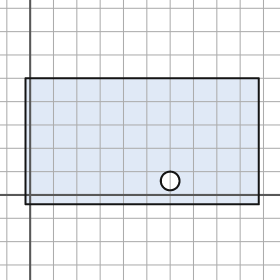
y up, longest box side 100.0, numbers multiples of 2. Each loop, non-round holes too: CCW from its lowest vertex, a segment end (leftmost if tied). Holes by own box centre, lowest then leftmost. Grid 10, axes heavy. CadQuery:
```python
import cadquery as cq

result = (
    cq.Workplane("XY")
    .moveTo(-2.0, -4.0)
    .lineTo(98.0, -4.0)
    .lineTo(98.0, 50.0)
    .lineTo(-2.0, 50.0)
    .close()
    .moveTo(60.0, 6.0)
    .circle(4.0)
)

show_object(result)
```